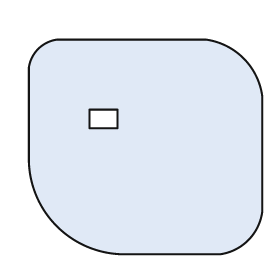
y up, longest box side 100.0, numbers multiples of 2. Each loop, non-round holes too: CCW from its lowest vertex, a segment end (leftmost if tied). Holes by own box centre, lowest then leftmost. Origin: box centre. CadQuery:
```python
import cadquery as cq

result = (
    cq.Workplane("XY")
    .moveTo(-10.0, -46.0)
    .lineTo(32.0, -46.0)
    .threePointArc((44.0, -40.0), (50.0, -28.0))
    .lineTo(50.0, 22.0)
    .threePointArc((42.0, 38.0), (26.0, 46.0))
    .lineTo(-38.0, 46.0)
    .threePointArc((-46.0, 42.0), (-50.0, 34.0))
    .lineTo(-50.0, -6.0)
    .threePointArc((-38.0, -34.0), (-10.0, -46.0))
    .close()
    .moveTo(-24.0, 8.0)
    .lineTo(-12.0, 8.0)
    .lineTo(-12.0, 16.0)
    .lineTo(-24.0, 16.0)
    .close()
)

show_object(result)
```